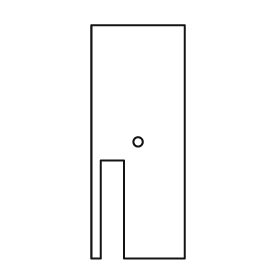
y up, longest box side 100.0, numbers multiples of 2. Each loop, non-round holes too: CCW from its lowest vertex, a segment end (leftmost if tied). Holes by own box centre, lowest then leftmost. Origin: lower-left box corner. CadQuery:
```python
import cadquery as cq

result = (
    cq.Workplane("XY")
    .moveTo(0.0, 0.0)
    .lineTo(4.0, 0.0)
    .lineTo(4.0, 42.0)
    .lineTo(14.0, 42.0)
    .lineTo(14.0, 0.0)
    .lineTo(40.0, 0.0)
    .lineTo(40.0, 100.0)
    .lineTo(0.0, 100.0)
    .close()
    .moveTo(20.0, 50.0)
    .circle(2.0)
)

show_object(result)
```